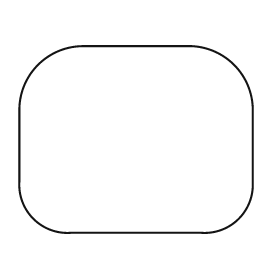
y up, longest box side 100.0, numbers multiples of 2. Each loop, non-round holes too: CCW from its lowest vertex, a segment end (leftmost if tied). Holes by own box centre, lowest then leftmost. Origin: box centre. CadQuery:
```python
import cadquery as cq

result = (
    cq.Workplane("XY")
    .moveTo(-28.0, -40.0)
    .lineTo(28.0, -40.0)
    .threePointArc((44.0, -34.0), (50.0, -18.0))
    .lineTo(50.0, 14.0)
    .threePointArc((42.0, 32.0), (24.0, 40.0))
    .lineTo(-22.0, 40.0)
    .threePointArc((-42.0, 32.0), (-50.0, 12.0))
    .lineTo(-50.0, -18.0)
    .threePointArc((-44.0, -34.0), (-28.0, -40.0))
    .close()
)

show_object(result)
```